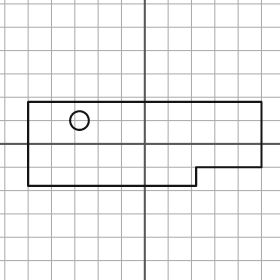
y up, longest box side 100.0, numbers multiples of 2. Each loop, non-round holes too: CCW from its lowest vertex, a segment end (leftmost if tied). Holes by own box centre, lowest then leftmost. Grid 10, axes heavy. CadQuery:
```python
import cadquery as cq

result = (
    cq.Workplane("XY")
    .moveTo(-50.0, -18.0)
    .lineTo(22.0, -18.0)
    .lineTo(22.0, -10.0)
    .lineTo(50.0, -10.0)
    .lineTo(50.0, 18.0)
    .lineTo(-50.0, 18.0)
    .close()
    .moveTo(-28.0, 10.0)
    .circle(4.0)
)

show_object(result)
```